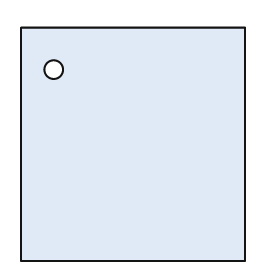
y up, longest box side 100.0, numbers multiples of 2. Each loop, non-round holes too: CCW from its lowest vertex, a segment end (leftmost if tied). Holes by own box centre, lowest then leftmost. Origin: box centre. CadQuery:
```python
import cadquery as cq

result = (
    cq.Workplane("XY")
    .moveTo(-48.0, -50.0)
    .lineTo(48.0, -50.0)
    .lineTo(48.0, 50.0)
    .lineTo(-48.0, 50.0)
    .close()
    .moveTo(-34.0, 32.0)
    .circle(4.0)
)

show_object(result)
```